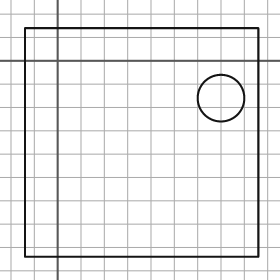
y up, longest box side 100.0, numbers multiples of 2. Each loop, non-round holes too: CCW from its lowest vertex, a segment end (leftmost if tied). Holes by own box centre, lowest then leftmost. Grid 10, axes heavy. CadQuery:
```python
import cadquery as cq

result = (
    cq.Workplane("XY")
    .moveTo(-14.0, -84.0)
    .lineTo(86.0, -84.0)
    .lineTo(86.0, 14.0)
    .lineTo(-14.0, 14.0)
    .close()
    .moveTo(70.0, -16.0)
    .circle(10.0)
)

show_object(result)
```